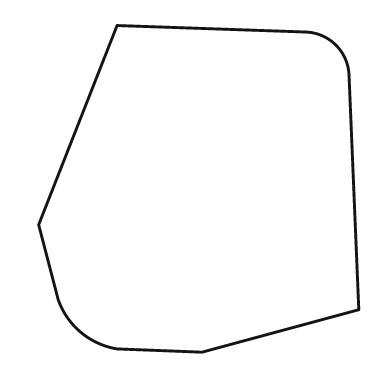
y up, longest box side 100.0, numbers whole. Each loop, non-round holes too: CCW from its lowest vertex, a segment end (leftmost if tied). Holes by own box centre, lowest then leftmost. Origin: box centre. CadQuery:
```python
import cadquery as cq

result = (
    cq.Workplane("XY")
    .moveTo(1.0, -50.0)
    .lineTo(49.0, -37.0)
    .lineTo(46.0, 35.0)
    .threePointArc((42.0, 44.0), (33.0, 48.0))
    .lineTo(-25.0, 50.0)
    .lineTo(-49.0, -11.0)
    .lineTo(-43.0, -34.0)
    .threePointArc((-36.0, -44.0), (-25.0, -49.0))
    .close()
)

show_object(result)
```